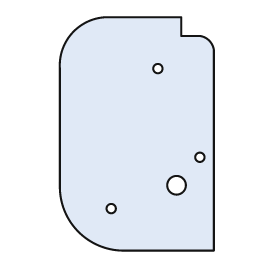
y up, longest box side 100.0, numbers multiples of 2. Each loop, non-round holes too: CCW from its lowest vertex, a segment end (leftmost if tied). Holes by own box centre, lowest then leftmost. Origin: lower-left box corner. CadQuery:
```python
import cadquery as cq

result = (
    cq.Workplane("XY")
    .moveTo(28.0, 0.0)
    .lineTo(66.0, 0.0)
    .lineTo(66.0, 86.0)
    .threePointArc((64.0, 90.0), (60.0, 92.0))
    .lineTo(52.0, 92.0)
    .lineTo(52.0, 100.0)
    .lineTo(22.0, 100.0)
    .threePointArc((6.0, 94.0), (0.0, 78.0))
    .lineTo(0.0, 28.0)
    .threePointArc((8.0, 8.0), (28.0, 0.0))
    .close()
    .moveTo(22.0, 18.0)
    .circle(2.0)
    .moveTo(50.0, 28.0)
    .circle(4.0)
    .moveTo(60.0, 40.0)
    .circle(2.0)
    .moveTo(42.0, 78.0)
    .circle(2.0)
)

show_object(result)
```